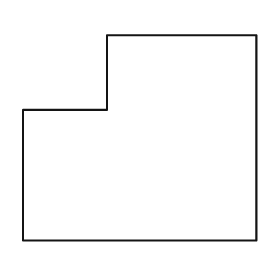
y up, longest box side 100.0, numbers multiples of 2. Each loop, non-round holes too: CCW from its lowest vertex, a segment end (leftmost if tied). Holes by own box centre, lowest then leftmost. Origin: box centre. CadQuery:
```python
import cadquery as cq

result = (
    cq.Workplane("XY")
    .moveTo(-50.0, -44.0)
    .lineTo(50.0, -44.0)
    .lineTo(50.0, 44.0)
    .lineTo(-14.0, 44.0)
    .lineTo(-14.0, 12.0)
    .lineTo(-50.0, 12.0)
    .close()
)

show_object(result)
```